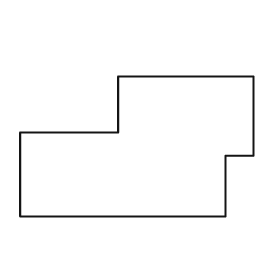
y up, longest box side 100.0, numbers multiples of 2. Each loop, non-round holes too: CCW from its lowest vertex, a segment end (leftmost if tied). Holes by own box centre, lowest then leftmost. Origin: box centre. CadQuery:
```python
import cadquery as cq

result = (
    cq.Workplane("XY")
    .moveTo(-50.0, -30.0)
    .lineTo(38.0, -30.0)
    .lineTo(38.0, -4.0)
    .lineTo(50.0, -4.0)
    .lineTo(50.0, 30.0)
    .lineTo(-8.0, 30.0)
    .lineTo(-8.0, 6.0)
    .lineTo(-50.0, 6.0)
    .close()
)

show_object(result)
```